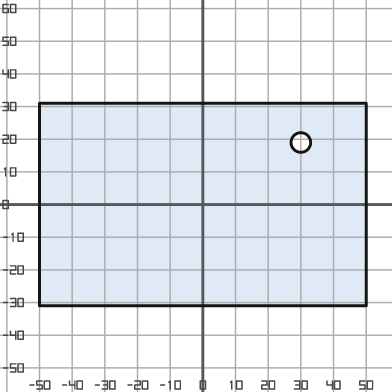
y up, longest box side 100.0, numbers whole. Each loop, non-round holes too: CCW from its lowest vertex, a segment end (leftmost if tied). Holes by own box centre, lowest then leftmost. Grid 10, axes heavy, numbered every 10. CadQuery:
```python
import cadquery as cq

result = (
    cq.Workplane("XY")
    .moveTo(-50.0, -31.0)
    .lineTo(50.0, -31.0)
    .lineTo(50.0, 31.0)
    .lineTo(-50.0, 31.0)
    .close()
    .moveTo(30.0, 19.0)
    .circle(3.0)
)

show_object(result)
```